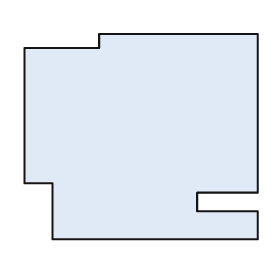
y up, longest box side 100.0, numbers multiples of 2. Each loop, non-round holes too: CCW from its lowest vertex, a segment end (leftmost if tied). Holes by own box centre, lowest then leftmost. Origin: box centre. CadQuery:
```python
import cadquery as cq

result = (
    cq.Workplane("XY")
    .moveTo(-38.0, -44.0)
    .lineTo(50.0, -44.0)
    .lineTo(50.0, -32.0)
    .lineTo(24.0, -32.0)
    .lineTo(24.0, -24.0)
    .lineTo(50.0, -24.0)
    .lineTo(50.0, 44.0)
    .lineTo(-18.0, 44.0)
    .lineTo(-18.0, 38.0)
    .lineTo(-50.0, 38.0)
    .lineTo(-50.0, -20.0)
    .lineTo(-38.0, -20.0)
    .close()
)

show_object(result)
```